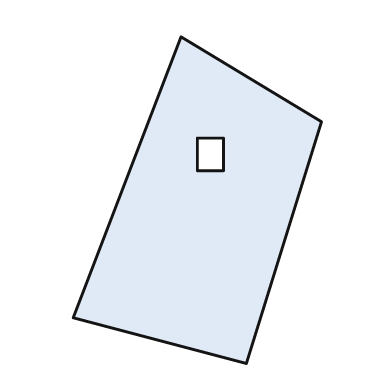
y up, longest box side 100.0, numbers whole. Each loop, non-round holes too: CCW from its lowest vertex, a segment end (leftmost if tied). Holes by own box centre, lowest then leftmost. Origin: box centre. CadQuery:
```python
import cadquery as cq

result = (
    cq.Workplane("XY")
    .moveTo(15.0, -50.0)
    .lineTo(38.0, 24.0)
    .lineTo(-5.0, 50.0)
    .lineTo(-38.0, -36.0)
    .close()
    .moveTo(0.0, 9.0)
    .lineTo(8.0, 9.0)
    .lineTo(8.0, 19.0)
    .lineTo(0.0, 19.0)
    .close()
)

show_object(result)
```